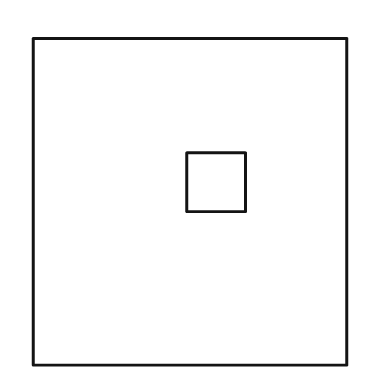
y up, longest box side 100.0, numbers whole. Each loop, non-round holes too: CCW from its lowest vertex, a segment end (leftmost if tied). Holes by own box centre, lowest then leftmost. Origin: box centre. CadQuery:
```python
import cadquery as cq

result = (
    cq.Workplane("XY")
    .moveTo(-48.0, -50.0)
    .lineTo(48.0, -50.0)
    .lineTo(48.0, 50.0)
    .lineTo(-48.0, 50.0)
    .close()
    .moveTo(-1.0, -3.0)
    .lineTo(17.0, -3.0)
    .lineTo(17.0, 15.0)
    .lineTo(-1.0, 15.0)
    .close()
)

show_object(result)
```